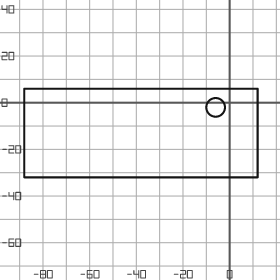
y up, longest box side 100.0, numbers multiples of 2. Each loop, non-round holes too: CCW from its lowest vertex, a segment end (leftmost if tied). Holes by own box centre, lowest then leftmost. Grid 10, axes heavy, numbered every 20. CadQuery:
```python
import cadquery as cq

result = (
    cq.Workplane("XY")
    .moveTo(-88.0, -32.0)
    .lineTo(12.0, -32.0)
    .lineTo(12.0, 6.0)
    .lineTo(-88.0, 6.0)
    .close()
    .moveTo(-6.0, -2.0)
    .circle(4.0)
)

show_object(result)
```